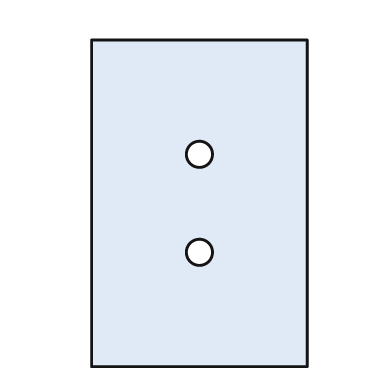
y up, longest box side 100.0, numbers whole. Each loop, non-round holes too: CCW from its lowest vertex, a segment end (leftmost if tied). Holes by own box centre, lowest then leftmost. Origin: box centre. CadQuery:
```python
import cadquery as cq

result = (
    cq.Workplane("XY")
    .moveTo(-33.0, -50.0)
    .lineTo(33.0, -50.0)
    .lineTo(33.0, 50.0)
    .lineTo(-33.0, 50.0)
    .close()
    .moveTo(0.0, -15.0)
    .circle(4.0)
    .moveTo(0.0, 15.0)
    .circle(4.0)
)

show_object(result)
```